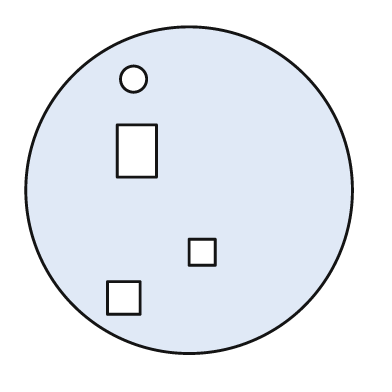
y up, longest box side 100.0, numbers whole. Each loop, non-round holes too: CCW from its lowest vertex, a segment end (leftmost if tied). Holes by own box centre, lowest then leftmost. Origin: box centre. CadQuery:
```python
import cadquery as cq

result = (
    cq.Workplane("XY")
    .moveTo(0.0, 0.0)
    .circle(50.0)
    .moveTo(-25.0, -38.0)
    .lineTo(-15.0, -38.0)
    .lineTo(-15.0, -28.0)
    .lineTo(-25.0, -28.0)
    .close()
    .moveTo(0.0, -23.0)
    .lineTo(8.0, -23.0)
    .lineTo(8.0, -15.0)
    .lineTo(0.0, -15.0)
    .close()
    .moveTo(-22.0, 4.0)
    .lineTo(-10.0, 4.0)
    .lineTo(-10.0, 20.0)
    .lineTo(-22.0, 20.0)
    .close()
    .moveTo(-17.0, 34.0)
    .circle(4.0)
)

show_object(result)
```